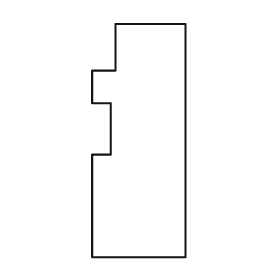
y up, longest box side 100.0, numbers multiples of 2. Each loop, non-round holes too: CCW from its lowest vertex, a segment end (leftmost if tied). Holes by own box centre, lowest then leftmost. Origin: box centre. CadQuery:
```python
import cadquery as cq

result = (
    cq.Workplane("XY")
    .moveTo(-20.0, -50.0)
    .lineTo(20.0, -50.0)
    .lineTo(20.0, 50.0)
    .lineTo(-10.0, 50.0)
    .lineTo(-10.0, 30.0)
    .lineTo(-20.0, 30.0)
    .lineTo(-20.0, 16.0)
    .lineTo(-12.0, 16.0)
    .lineTo(-12.0, -6.0)
    .lineTo(-20.0, -6.0)
    .close()
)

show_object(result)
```